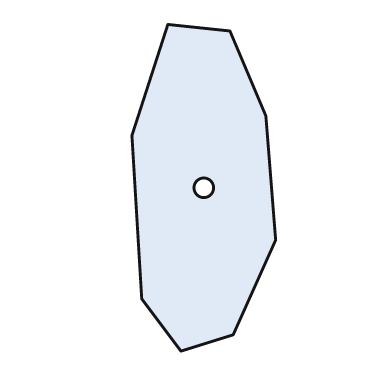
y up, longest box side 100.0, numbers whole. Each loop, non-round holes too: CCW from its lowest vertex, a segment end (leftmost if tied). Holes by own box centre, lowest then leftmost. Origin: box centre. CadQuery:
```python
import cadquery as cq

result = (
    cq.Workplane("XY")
    .moveTo(-7.0, -50.0)
    .lineTo(9.0, -45.0)
    .lineTo(22.0, -16.0)
    .lineTo(19.0, 22.0)
    .lineTo(8.0, 48.0)
    .lineTo(-11.0, 50.0)
    .lineTo(-22.0, 16.0)
    .lineTo(-19.0, -34.0)
    .close()
    .moveTo(0.0, 0.0)
    .circle(3.0)
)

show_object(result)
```